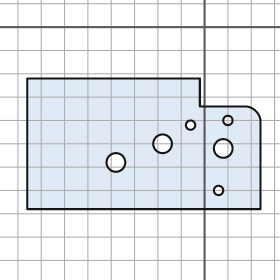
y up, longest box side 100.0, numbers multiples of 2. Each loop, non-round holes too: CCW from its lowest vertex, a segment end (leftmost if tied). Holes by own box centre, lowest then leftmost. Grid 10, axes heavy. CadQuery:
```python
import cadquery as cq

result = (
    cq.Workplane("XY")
    .moveTo(-76.0, -78.0)
    .lineTo(24.0, -78.0)
    .lineTo(24.0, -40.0)
    .threePointArc((22.0, -36.0), (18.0, -34.0))
    .lineTo(-2.0, -34.0)
    .lineTo(-2.0, -22.0)
    .lineTo(-76.0, -22.0)
    .close()
    .moveTo(6.0, -70.0)
    .circle(2.0)
    .moveTo(-38.0, -58.0)
    .circle(4.0)
    .moveTo(8.0, -52.0)
    .circle(4.0)
    .moveTo(-18.0, -50.0)
    .circle(4.0)
    .moveTo(-6.0, -42.0)
    .circle(2.0)
    .moveTo(10.0, -40.0)
    .circle(2.0)
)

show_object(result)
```